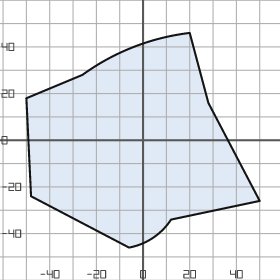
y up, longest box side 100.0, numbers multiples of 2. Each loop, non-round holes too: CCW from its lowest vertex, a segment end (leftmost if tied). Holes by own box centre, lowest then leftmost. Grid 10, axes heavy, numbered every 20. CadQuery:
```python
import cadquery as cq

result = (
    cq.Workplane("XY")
    .moveTo(-6.0, -46.0)
    .threePointArc((4.0, -42.0), (12.0, -34.0))
    .lineTo(50.0, -26.0)
    .lineTo(28.0, 16.0)
    .lineTo(20.0, 46.0)
    .threePointArc((-4.0, 40.0), (-26.0, 28.0))
    .lineTo(-50.0, 18.0)
    .lineTo(-48.0, -24.0)
    .close()
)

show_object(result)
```